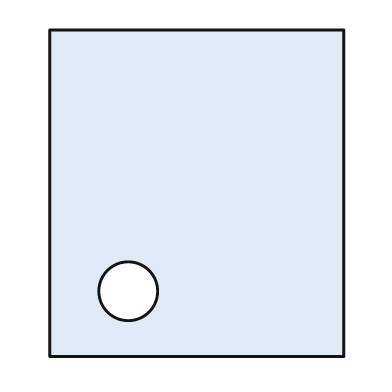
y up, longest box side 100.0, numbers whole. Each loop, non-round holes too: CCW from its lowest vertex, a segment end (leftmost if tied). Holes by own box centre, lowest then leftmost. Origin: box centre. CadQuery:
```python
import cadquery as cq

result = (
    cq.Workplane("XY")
    .moveTo(-45.0, -50.0)
    .lineTo(45.0, -50.0)
    .lineTo(45.0, 50.0)
    .lineTo(-45.0, 50.0)
    .close()
    .moveTo(-21.0, -30.0)
    .circle(9.0)
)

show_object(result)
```